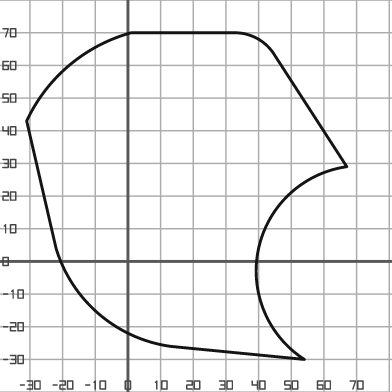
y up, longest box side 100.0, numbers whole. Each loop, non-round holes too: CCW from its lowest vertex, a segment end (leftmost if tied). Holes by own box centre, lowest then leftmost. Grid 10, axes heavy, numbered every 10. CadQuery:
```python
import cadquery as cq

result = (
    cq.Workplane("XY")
    .moveTo(54.0, -30.0)
    .threePointArc((40.0, 4.0), (67.0, 29.0))
    .lineTo(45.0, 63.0)
    .threePointArc((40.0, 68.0), (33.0, 70.0))
    .lineTo(1.0, 70.0)
    .threePointArc((-18.0, 60.0), (-31.0, 43.0))
    .lineTo(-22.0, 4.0)
    .threePointArc((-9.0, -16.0), (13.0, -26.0))
    .close()
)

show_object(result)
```